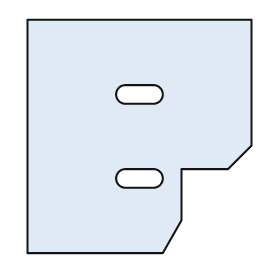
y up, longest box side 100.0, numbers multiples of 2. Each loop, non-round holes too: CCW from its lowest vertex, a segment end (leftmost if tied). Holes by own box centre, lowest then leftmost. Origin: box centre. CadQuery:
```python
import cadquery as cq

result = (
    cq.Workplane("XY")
    .moveTo(-48.0, -50.0)
    .lineTo(10.0, -50.0)
    .lineTo(18.0, -36.0)
    .lineTo(18.0, -14.0)
    .lineTo(38.0, -14.0)
    .lineTo(48.0, -4.0)
    .lineTo(48.0, 50.0)
    .lineTo(-48.0, 50.0)
    .close()
    .moveTo(-6.0, -22.0)
    .lineTo(6.0, -22.0)
    .threePointArc((10.0, -18.0), (6.0, -14.0))
    .lineTo(-6.0, -14.0)
    .threePointArc((-10.0, -18.0), (-6.0, -22.0))
    .close()
    .moveTo(-6.0, 14.0)
    .lineTo(6.0, 14.0)
    .threePointArc((10.0, 18.0), (6.0, 22.0))
    .lineTo(-6.0, 22.0)
    .threePointArc((-10.0, 18.0), (-6.0, 14.0))
    .close()
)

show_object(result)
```